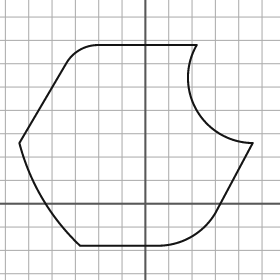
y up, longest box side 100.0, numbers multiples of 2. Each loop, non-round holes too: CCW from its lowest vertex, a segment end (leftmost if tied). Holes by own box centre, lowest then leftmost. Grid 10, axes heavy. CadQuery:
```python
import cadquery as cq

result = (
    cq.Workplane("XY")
    .moveTo(-28.0, -18.0)
    .lineTo(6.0, -18.0)
    .threePointArc((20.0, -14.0), (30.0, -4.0))
    .lineTo(46.0, 26.0)
    .threePointArc((22.0, 40.0), (22.0, 68.0))
    .lineTo(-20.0, 68.0)
    .threePointArc((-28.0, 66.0), (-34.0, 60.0))
    .lineTo(-54.0, 26.0)
    .threePointArc((-44.0, 2.0), (-28.0, -18.0))
    .close()
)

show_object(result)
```